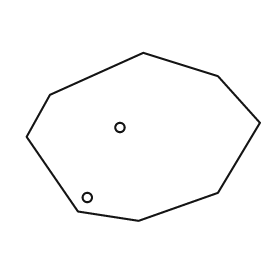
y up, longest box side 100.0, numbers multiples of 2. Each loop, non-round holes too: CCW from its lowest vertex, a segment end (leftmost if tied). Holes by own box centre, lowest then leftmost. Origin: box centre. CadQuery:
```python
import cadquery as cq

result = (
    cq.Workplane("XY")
    .moveTo(-2.0, -36.0)
    .lineTo(32.0, -24.0)
    .lineTo(50.0, 6.0)
    .lineTo(32.0, 26.0)
    .lineTo(0.0, 36.0)
    .lineTo(-40.0, 18.0)
    .lineTo(-50.0, 0.0)
    .lineTo(-28.0, -32.0)
    .close()
    .moveTo(-24.0, -26.0)
    .circle(2.0)
    .moveTo(-10.0, 4.0)
    .circle(2.0)
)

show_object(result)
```